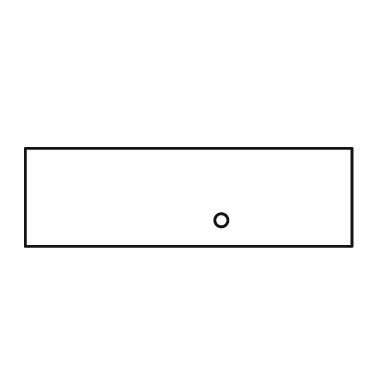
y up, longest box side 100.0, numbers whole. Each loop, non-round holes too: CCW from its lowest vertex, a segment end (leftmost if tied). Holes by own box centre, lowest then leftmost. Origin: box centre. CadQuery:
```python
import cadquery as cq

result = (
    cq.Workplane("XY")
    .moveTo(-50.0, -15.0)
    .lineTo(50.0, -15.0)
    .lineTo(50.0, 15.0)
    .lineTo(-50.0, 15.0)
    .close()
    .moveTo(10.0, -7.0)
    .circle(2.0)
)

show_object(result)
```